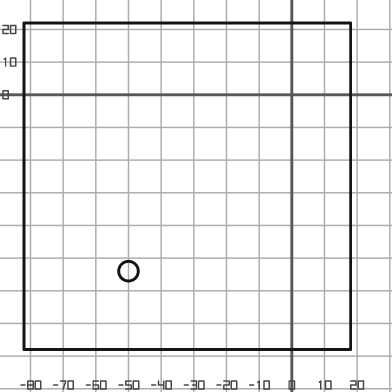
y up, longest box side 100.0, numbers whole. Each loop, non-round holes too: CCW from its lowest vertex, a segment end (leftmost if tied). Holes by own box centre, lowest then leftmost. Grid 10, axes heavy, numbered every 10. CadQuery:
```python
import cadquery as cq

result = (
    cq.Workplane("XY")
    .moveTo(-82.0, -78.0)
    .lineTo(18.0, -78.0)
    .lineTo(18.0, 22.0)
    .lineTo(-82.0, 22.0)
    .close()
    .moveTo(-50.0, -54.0)
    .circle(3.0)
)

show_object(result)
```